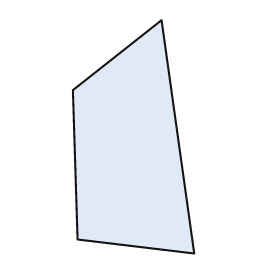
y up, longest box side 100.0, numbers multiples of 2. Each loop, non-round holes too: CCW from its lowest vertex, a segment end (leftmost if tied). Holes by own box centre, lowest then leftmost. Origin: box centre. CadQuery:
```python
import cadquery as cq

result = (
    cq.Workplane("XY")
    .moveTo(26.0, -50.0)
    .lineTo(12.0, 50.0)
    .lineTo(-26.0, 20.0)
    .lineTo(-24.0, -44.0)
    .close()
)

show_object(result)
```